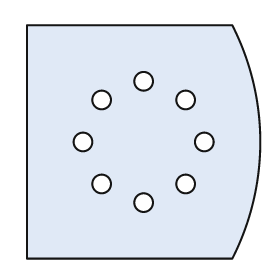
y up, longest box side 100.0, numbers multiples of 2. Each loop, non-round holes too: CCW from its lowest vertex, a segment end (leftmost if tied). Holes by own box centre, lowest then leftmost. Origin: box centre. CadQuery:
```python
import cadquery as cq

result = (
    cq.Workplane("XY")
    .moveTo(-50.0, -50.0)
    .lineTo(38.0, -50.0)
    .threePointArc((50.0, 0.0), (38.0, 50.0))
    .lineTo(-50.0, 50.0)
    .close()
    .moveTo(0.0, -26.0)
    .circle(4.0)
    .moveTo(-18.0, -18.0)
    .circle(4.0)
    .moveTo(18.0, -18.0)
    .circle(4.0)
    .moveTo(-26.0, 0.0)
    .circle(4.0)
    .moveTo(26.0, 0.0)
    .circle(4.0)
    .moveTo(-18.0, 18.0)
    .circle(4.0)
    .moveTo(18.0, 18.0)
    .circle(4.0)
    .moveTo(0.0, 26.0)
    .circle(4.0)
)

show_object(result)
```